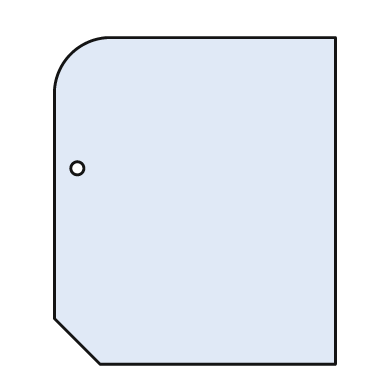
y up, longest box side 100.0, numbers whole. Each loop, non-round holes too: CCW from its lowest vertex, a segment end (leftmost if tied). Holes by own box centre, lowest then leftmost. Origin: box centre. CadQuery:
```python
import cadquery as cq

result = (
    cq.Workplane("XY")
    .moveTo(-29.0, -50.0)
    .lineTo(43.0, -50.0)
    .lineTo(43.0, 50.0)
    .lineTo(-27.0, 50.0)
    .threePointArc((-38.0, 45.0), (-43.0, 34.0))
    .lineTo(-43.0, -36.0)
    .close()
    .moveTo(-36.0, 10.0)
    .circle(2.0)
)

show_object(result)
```